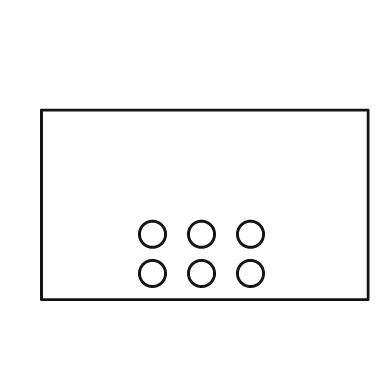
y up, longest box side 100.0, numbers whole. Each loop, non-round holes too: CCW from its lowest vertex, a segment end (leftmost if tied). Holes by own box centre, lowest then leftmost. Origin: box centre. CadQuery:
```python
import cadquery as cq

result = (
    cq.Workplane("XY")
    .moveTo(-50.0, -29.0)
    .lineTo(50.0, -29.0)
    .lineTo(50.0, 29.0)
    .lineTo(-50.0, 29.0)
    .close()
    .moveTo(-16.0, -21.0)
    .circle(4.0)
    .moveTo(-1.0, -21.0)
    .circle(4.0)
    .moveTo(14.0, -21.0)
    .circle(4.0)
    .moveTo(-16.0, -9.0)
    .circle(4.0)
    .moveTo(-1.0, -9.0)
    .circle(4.0)
    .moveTo(14.0, -9.0)
    .circle(4.0)
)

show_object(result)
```